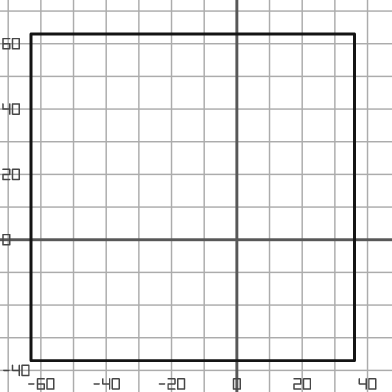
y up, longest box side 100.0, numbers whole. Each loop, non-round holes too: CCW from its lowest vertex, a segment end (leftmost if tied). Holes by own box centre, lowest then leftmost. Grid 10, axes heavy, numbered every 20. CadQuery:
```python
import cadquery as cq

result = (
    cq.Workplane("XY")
    .moveTo(-63.0, -37.0)
    .lineTo(36.0, -37.0)
    .lineTo(36.0, 63.0)
    .lineTo(-63.0, 63.0)
    .close()
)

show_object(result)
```